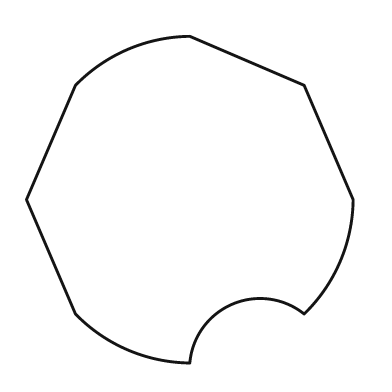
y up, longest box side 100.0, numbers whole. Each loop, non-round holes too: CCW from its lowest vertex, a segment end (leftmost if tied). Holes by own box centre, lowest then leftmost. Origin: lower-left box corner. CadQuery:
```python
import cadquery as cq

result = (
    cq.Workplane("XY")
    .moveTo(50.0, 0.0)
    .threePointArc((63.0, 18.0), (85.0, 15.0))
    .threePointArc((96.0, 31.0), (100.0, 50.0))
    .lineTo(85.0, 85.0)
    .lineTo(50.0, 100.0)
    .threePointArc((31.0, 96.0), (15.0, 85.0))
    .lineTo(0.0, 50.0)
    .lineTo(15.0, 15.0)
    .threePointArc((31.0, 4.0), (50.0, 0.0))
    .close()
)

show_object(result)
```